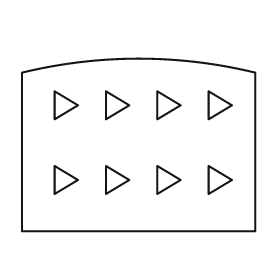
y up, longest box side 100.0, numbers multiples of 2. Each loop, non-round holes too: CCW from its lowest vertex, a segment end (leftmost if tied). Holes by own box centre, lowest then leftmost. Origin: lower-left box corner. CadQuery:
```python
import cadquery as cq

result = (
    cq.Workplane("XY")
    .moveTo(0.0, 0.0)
    .lineTo(100.0, 0.0)
    .lineTo(100.0, 68.0)
    .threePointArc((50.0, 74.0), (0.0, 68.0))
    .close()
    .moveTo(14.0, 16.0)
    .lineTo(24.0, 22.0)
    .lineTo(14.0, 28.0)
    .close()
    .moveTo(36.0, 16.0)
    .lineTo(46.0, 22.0)
    .lineTo(36.0, 28.0)
    .close()
    .moveTo(58.0, 16.0)
    .lineTo(68.0, 22.0)
    .lineTo(58.0, 28.0)
    .close()
    .moveTo(80.0, 16.0)
    .lineTo(90.0, 22.0)
    .lineTo(80.0, 28.0)
    .close()
    .moveTo(14.0, 48.0)
    .lineTo(24.0, 54.0)
    .lineTo(14.0, 60.0)
    .close()
    .moveTo(36.0, 48.0)
    .lineTo(46.0, 54.0)
    .lineTo(36.0, 60.0)
    .close()
    .moveTo(58.0, 48.0)
    .lineTo(68.0, 54.0)
    .lineTo(58.0, 60.0)
    .close()
    .moveTo(80.0, 48.0)
    .lineTo(90.0, 54.0)
    .lineTo(80.0, 60.0)
    .close()
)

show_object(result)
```